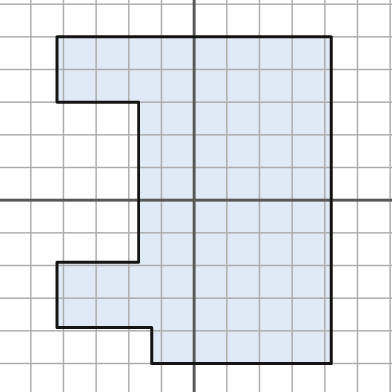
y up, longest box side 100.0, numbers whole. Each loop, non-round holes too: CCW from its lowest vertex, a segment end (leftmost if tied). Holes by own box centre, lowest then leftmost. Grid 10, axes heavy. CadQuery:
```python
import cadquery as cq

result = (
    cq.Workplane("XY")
    .moveTo(-13.0, -50.0)
    .lineTo(42.0, -50.0)
    .lineTo(42.0, 50.0)
    .lineTo(-42.0, 50.0)
    .lineTo(-42.0, 30.0)
    .lineTo(-17.0, 30.0)
    .lineTo(-17.0, -19.0)
    .lineTo(-42.0, -19.0)
    .lineTo(-42.0, -39.0)
    .lineTo(-13.0, -39.0)
    .close()
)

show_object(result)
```